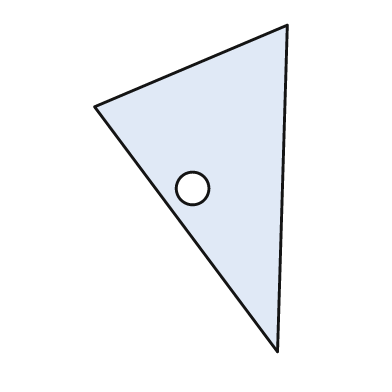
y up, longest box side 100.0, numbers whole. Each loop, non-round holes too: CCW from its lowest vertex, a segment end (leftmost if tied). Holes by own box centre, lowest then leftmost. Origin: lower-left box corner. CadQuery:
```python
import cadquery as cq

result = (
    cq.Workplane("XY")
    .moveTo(56.0, 0.0)
    .lineTo(59.0, 100.0)
    .lineTo(0.0, 75.0)
    .close()
    .moveTo(30.0, 50.0)
    .circle(5.0)
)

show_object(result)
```